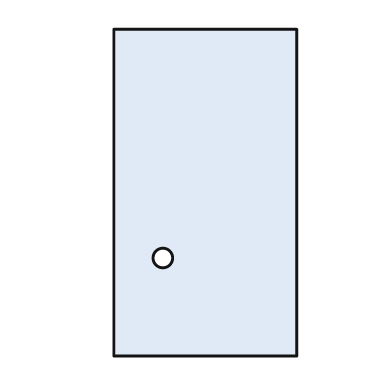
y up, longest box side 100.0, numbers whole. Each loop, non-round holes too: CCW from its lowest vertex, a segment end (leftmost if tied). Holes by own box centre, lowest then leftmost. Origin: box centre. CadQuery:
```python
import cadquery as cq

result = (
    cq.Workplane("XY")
    .moveTo(-28.0, -50.0)
    .lineTo(28.0, -50.0)
    .lineTo(28.0, 50.0)
    .lineTo(-28.0, 50.0)
    .close()
    .moveTo(-13.0, -20.0)
    .circle(3.0)
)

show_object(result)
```